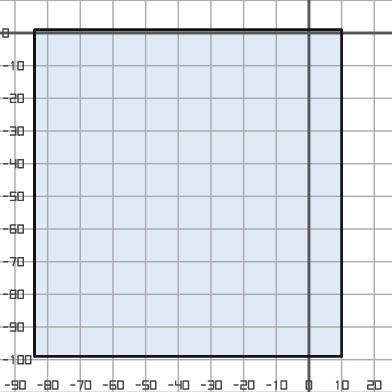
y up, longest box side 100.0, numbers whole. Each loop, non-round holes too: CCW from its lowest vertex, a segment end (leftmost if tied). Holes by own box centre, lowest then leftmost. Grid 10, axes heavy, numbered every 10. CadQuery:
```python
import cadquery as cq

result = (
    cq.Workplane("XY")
    .moveTo(-84.0, -99.0)
    .lineTo(10.0, -99.0)
    .lineTo(10.0, 1.0)
    .lineTo(-84.0, 1.0)
    .close()
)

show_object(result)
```